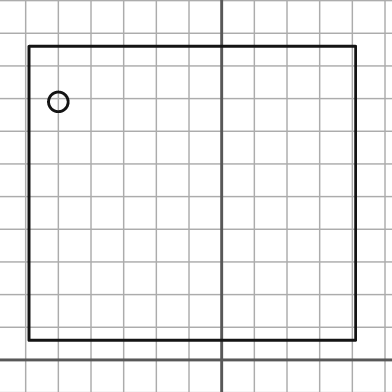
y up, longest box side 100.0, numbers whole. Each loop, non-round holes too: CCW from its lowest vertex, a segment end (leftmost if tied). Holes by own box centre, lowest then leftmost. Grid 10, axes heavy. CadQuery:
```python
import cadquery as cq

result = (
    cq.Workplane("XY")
    .moveTo(-59.0, 6.0)
    .lineTo(41.0, 6.0)
    .lineTo(41.0, 96.0)
    .lineTo(-59.0, 96.0)
    .close()
    .moveTo(-50.0, 79.0)
    .circle(3.0)
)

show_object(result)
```